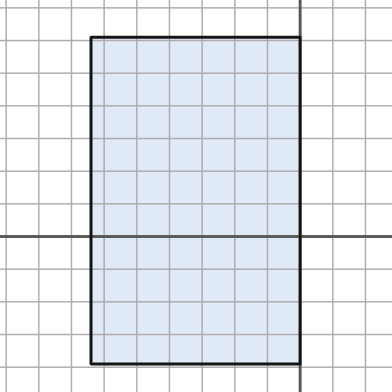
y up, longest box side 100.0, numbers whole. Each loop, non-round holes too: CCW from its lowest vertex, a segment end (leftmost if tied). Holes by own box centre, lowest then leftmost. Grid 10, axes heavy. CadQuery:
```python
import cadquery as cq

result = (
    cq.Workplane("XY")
    .moveTo(-64.0, -39.0)
    .lineTo(0.0, -39.0)
    .lineTo(0.0, 61.0)
    .lineTo(-64.0, 61.0)
    .close()
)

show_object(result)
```